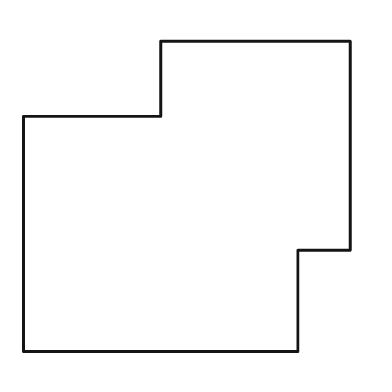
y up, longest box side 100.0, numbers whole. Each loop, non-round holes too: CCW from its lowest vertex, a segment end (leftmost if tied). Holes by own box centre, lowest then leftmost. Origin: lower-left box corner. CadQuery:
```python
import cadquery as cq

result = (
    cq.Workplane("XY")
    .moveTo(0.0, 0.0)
    .lineTo(84.0, 0.0)
    .lineTo(84.0, 31.0)
    .lineTo(100.0, 31.0)
    .lineTo(100.0, 95.0)
    .lineTo(42.0, 95.0)
    .lineTo(42.0, 72.0)
    .lineTo(0.0, 72.0)
    .close()
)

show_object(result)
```